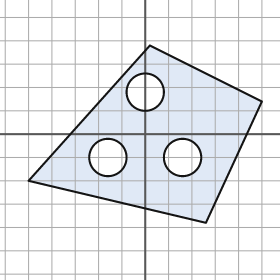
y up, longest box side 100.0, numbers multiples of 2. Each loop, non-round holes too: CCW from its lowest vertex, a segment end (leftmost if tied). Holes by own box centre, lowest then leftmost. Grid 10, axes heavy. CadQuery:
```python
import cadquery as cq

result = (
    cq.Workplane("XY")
    .moveTo(26.0, -38.0)
    .lineTo(50.0, 14.0)
    .lineTo(2.0, 38.0)
    .lineTo(-50.0, -20.0)
    .close()
    .moveTo(-16.0, -10.0)
    .circle(8.0)
    .moveTo(16.0, -10.0)
    .circle(8.0)
    .moveTo(0.0, 18.0)
    .circle(8.0)
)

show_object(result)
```